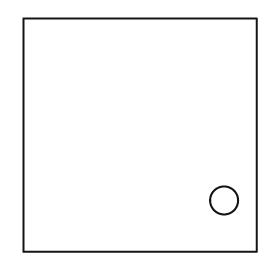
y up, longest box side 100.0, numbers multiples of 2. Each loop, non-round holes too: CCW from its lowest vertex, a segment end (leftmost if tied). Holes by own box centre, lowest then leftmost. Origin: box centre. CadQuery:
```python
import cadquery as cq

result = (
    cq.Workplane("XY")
    .moveTo(-50.0, -50.0)
    .lineTo(50.0, -50.0)
    .lineTo(50.0, 50.0)
    .lineTo(-50.0, 50.0)
    .close()
    .moveTo(36.0, -28.0)
    .circle(6.0)
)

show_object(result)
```